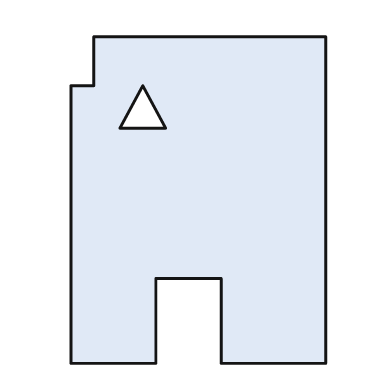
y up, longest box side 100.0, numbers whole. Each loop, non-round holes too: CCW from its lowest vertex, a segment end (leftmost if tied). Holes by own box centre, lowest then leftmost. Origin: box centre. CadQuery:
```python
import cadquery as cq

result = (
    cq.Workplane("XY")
    .moveTo(-39.0, -50.0)
    .lineTo(-13.0, -50.0)
    .lineTo(-13.0, -24.0)
    .lineTo(7.0, -24.0)
    .lineTo(7.0, -50.0)
    .lineTo(39.0, -50.0)
    .lineTo(39.0, 50.0)
    .lineTo(-32.0, 50.0)
    .lineTo(-32.0, 35.0)
    .lineTo(-39.0, 35.0)
    .close()
    .moveTo(-24.0, 22.0)
    .lineTo(-10.0, 22.0)
    .lineTo(-17.0, 35.0)
    .close()
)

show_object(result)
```